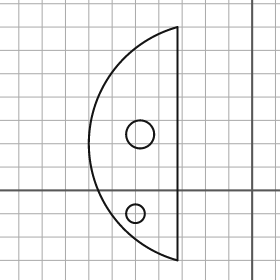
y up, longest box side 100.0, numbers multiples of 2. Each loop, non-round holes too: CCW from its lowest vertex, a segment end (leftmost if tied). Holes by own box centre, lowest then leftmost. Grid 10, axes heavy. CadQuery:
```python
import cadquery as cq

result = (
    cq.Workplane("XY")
    .moveTo(-32.0, -30.0)
    .lineTo(-32.0, 70.0)
    .threePointArc((-70.0, 20.0), (-32.0, -30.0))
    .close()
    .moveTo(-50.0, -10.0)
    .circle(4.0)
    .moveTo(-48.0, 24.0)
    .circle(6.0)
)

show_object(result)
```